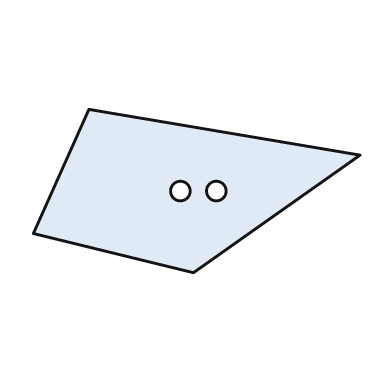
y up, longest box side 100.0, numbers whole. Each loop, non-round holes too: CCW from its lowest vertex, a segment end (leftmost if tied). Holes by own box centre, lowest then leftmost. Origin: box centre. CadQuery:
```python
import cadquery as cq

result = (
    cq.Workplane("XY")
    .moveTo(-1.0, -25.0)
    .lineTo(50.0, 11.0)
    .lineTo(-33.0, 25.0)
    .lineTo(-50.0, -13.0)
    .close()
    .moveTo(-5.0, 0.0)
    .circle(3.0)
    .moveTo(6.0, 0.0)
    .circle(3.0)
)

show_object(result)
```